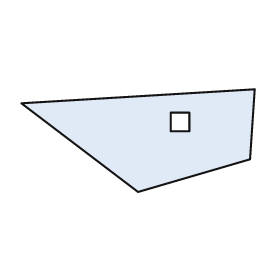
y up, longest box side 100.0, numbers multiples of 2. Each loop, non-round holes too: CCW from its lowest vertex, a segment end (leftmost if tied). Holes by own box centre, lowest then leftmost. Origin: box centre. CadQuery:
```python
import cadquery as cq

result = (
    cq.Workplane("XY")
    .moveTo(0.0, -22.0)
    .lineTo(48.0, -8.0)
    .lineTo(50.0, 22.0)
    .lineTo(-50.0, 16.0)
    .close()
    .moveTo(14.0, 4.0)
    .lineTo(22.0, 4.0)
    .lineTo(22.0, 12.0)
    .lineTo(14.0, 12.0)
    .close()
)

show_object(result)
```